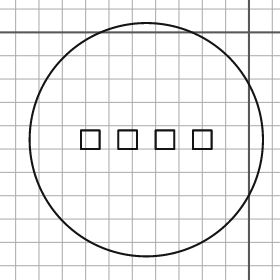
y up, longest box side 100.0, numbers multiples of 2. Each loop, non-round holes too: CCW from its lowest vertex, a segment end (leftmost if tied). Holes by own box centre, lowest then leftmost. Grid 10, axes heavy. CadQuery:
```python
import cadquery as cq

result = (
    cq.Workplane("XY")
    .moveTo(-44.0, -46.0)
    .circle(50.0)
    .moveTo(-72.0, -50.0)
    .lineTo(-64.0, -50.0)
    .lineTo(-64.0, -42.0)
    .lineTo(-72.0, -42.0)
    .close()
    .moveTo(-56.0, -50.0)
    .lineTo(-48.0, -50.0)
    .lineTo(-48.0, -42.0)
    .lineTo(-56.0, -42.0)
    .close()
    .moveTo(-40.0, -50.0)
    .lineTo(-32.0, -50.0)
    .lineTo(-32.0, -42.0)
    .lineTo(-40.0, -42.0)
    .close()
    .moveTo(-24.0, -50.0)
    .lineTo(-16.0, -50.0)
    .lineTo(-16.0, -42.0)
    .lineTo(-24.0, -42.0)
    .close()
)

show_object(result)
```